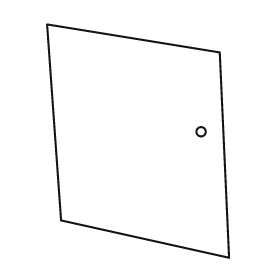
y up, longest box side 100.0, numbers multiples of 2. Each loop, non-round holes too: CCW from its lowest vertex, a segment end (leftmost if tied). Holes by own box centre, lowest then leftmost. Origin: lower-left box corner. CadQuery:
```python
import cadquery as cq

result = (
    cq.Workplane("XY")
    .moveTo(78.0, 0.0)
    .lineTo(74.0, 88.0)
    .lineTo(0.0, 100.0)
    .lineTo(6.0, 16.0)
    .close()
    .moveTo(66.0, 54.0)
    .circle(2.0)
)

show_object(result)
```